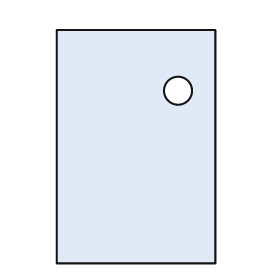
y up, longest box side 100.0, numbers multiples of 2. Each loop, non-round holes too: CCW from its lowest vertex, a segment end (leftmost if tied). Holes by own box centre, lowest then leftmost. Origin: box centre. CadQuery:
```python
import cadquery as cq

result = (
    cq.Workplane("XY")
    .moveTo(-34.0, -50.0)
    .lineTo(34.0, -50.0)
    .lineTo(34.0, 50.0)
    .lineTo(-34.0, 50.0)
    .close()
    .moveTo(18.0, 24.0)
    .circle(6.0)
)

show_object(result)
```